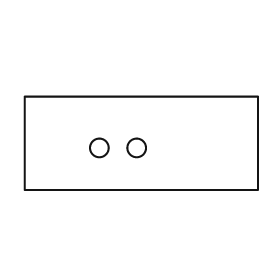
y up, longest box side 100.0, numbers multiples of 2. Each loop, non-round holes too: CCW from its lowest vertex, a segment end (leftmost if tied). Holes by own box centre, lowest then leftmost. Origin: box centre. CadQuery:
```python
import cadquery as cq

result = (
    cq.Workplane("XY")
    .moveTo(-50.0, -20.0)
    .lineTo(50.0, -20.0)
    .lineTo(50.0, 20.0)
    .lineTo(-50.0, 20.0)
    .close()
    .moveTo(-18.0, -2.0)
    .circle(4.0)
    .moveTo(-2.0, -2.0)
    .circle(4.0)
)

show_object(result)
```